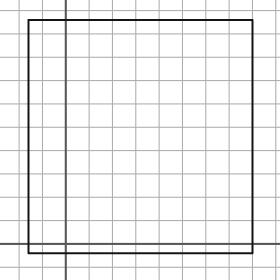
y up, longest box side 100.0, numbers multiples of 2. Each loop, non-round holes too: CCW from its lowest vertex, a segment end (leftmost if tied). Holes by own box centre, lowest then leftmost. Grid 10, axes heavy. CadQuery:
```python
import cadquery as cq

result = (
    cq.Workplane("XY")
    .moveTo(-16.0, -4.0)
    .lineTo(80.0, -4.0)
    .lineTo(80.0, 96.0)
    .lineTo(-16.0, 96.0)
    .close()
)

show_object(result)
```